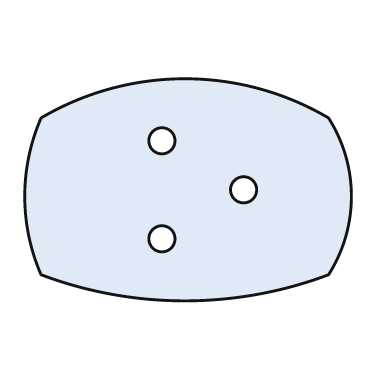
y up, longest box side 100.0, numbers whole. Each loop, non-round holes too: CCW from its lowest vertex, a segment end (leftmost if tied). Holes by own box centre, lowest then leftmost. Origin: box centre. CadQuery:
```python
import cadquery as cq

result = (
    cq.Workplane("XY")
    .moveTo(-45.0, -26.0)
    .threePointArc((-1.0, -34.0), (43.0, -26.0))
    .threePointArc((50.0, -2.0), (43.0, 22.0))
    .threePointArc((-1.0, 34.0), (-45.0, 22.0))
    .threePointArc((-50.0, -2.0), (-45.0, -26.0))
    .close()
    .moveTo(-8.0, -15.0)
    .circle(4.0)
    .moveTo(17.0, 0.0)
    .circle(4.0)
    .moveTo(-8.0, 15.0)
    .circle(4.0)
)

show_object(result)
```